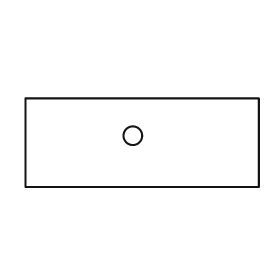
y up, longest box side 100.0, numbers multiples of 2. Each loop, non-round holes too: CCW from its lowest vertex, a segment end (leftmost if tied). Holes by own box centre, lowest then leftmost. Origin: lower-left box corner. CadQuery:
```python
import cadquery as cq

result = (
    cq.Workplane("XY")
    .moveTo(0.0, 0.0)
    .lineTo(100.0, 0.0)
    .lineTo(100.0, 38.0)
    .lineTo(0.0, 38.0)
    .close()
    .moveTo(46.0, 22.0)
    .circle(4.0)
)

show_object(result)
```